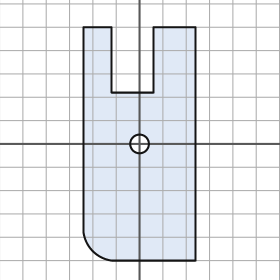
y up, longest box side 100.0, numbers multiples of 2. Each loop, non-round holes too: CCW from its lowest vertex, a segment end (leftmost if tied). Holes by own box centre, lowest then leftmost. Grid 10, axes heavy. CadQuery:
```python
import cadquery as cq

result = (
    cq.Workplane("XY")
    .moveTo(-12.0, -50.0)
    .lineTo(24.0, -50.0)
    .lineTo(24.0, 50.0)
    .lineTo(6.0, 50.0)
    .lineTo(6.0, 22.0)
    .lineTo(-12.0, 22.0)
    .lineTo(-12.0, 50.0)
    .lineTo(-24.0, 50.0)
    .lineTo(-24.0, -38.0)
    .threePointArc((-20.0, -46.0), (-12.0, -50.0))
    .close()
    .moveTo(0.0, 0.0)
    .circle(4.0)
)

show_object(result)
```